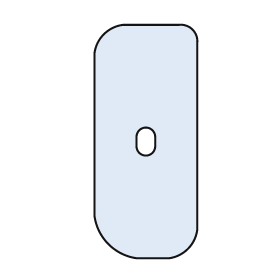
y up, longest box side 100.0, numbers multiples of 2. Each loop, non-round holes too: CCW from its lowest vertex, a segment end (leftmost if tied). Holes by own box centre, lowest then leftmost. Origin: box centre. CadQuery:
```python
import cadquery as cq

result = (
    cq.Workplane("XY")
    .moveTo(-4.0, -50.0)
    .lineTo(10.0, -50.0)
    .threePointArc((18.0, -46.0), (22.0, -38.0))
    .lineTo(22.0, 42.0)
    .threePointArc((20.0, 48.0), (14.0, 50.0))
    .lineTo(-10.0, 50.0)
    .threePointArc((-18.0, 46.0), (-22.0, 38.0))
    .lineTo(-22.0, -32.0)
    .threePointArc((-16.0, -44.0), (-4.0, -50.0))
    .close()
    .moveTo(-4.0, -2.0)
    .threePointArc((0.0, -6.0), (4.0, -2.0))
    .lineTo(4.0, 2.0)
    .threePointArc((0.0, 6.0), (-4.0, 2.0))
    .close()
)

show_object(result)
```